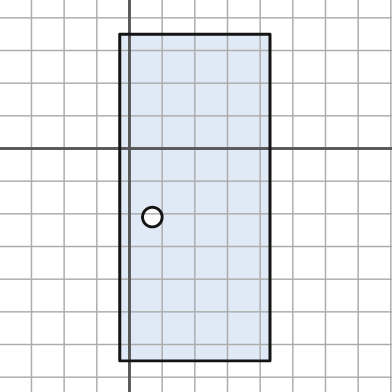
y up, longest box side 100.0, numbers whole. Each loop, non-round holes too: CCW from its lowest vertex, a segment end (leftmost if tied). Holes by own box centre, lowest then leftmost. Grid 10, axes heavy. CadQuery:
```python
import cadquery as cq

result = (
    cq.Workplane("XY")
    .moveTo(-3.0, -65.0)
    .lineTo(43.0, -65.0)
    .lineTo(43.0, 35.0)
    .lineTo(-3.0, 35.0)
    .close()
    .moveTo(7.0, -21.0)
    .circle(3.0)
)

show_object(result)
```